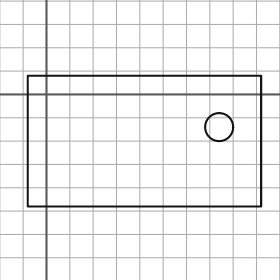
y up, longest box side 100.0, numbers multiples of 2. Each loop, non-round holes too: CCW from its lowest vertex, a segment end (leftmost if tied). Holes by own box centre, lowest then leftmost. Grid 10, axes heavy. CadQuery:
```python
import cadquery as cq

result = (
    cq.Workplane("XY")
    .moveTo(-8.0, -48.0)
    .lineTo(92.0, -48.0)
    .lineTo(92.0, 8.0)
    .lineTo(-8.0, 8.0)
    .close()
    .moveTo(74.0, -14.0)
    .circle(6.0)
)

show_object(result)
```